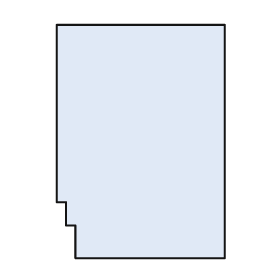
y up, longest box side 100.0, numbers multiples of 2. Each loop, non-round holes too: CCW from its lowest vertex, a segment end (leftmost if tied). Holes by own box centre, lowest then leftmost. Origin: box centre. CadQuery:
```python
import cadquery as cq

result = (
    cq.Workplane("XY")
    .moveTo(-28.0, -50.0)
    .lineTo(36.0, -50.0)
    .lineTo(36.0, 50.0)
    .lineTo(-36.0, 50.0)
    .lineTo(-36.0, -26.0)
    .lineTo(-32.0, -26.0)
    .lineTo(-32.0, -36.0)
    .lineTo(-28.0, -36.0)
    .close()
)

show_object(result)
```